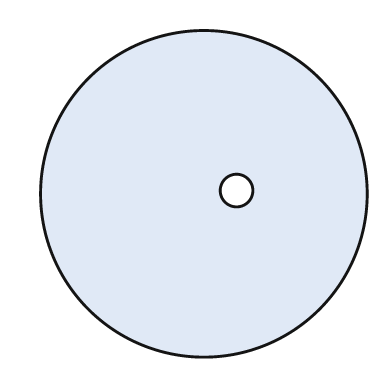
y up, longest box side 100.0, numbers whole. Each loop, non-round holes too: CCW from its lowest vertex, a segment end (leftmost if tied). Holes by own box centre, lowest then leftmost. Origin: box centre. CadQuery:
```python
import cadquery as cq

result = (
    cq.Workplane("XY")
    .moveTo(0.0, 0.0)
    .circle(50.0)
    .moveTo(10.0, 1.0)
    .circle(5.0)
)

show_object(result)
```